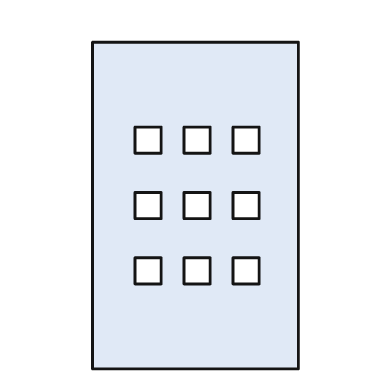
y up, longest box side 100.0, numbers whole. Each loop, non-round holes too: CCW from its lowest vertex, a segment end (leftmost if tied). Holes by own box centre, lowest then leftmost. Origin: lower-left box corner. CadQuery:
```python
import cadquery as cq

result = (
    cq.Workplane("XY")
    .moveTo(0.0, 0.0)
    .lineTo(63.0, 0.0)
    .lineTo(63.0, 100.0)
    .lineTo(0.0, 100.0)
    .close()
    .moveTo(13.0, 26.0)
    .lineTo(21.0, 26.0)
    .lineTo(21.0, 34.0)
    .lineTo(13.0, 34.0)
    .close()
    .moveTo(28.0, 26.0)
    .lineTo(36.0, 26.0)
    .lineTo(36.0, 34.0)
    .lineTo(28.0, 34.0)
    .close()
    .moveTo(43.0, 26.0)
    .lineTo(51.0, 26.0)
    .lineTo(51.0, 34.0)
    .lineTo(43.0, 34.0)
    .close()
    .moveTo(13.0, 46.0)
    .lineTo(21.0, 46.0)
    .lineTo(21.0, 54.0)
    .lineTo(13.0, 54.0)
    .close()
    .moveTo(28.0, 46.0)
    .lineTo(36.0, 46.0)
    .lineTo(36.0, 54.0)
    .lineTo(28.0, 54.0)
    .close()
    .moveTo(43.0, 46.0)
    .lineTo(51.0, 46.0)
    .lineTo(51.0, 54.0)
    .lineTo(43.0, 54.0)
    .close()
    .moveTo(13.0, 66.0)
    .lineTo(21.0, 66.0)
    .lineTo(21.0, 74.0)
    .lineTo(13.0, 74.0)
    .close()
    .moveTo(28.0, 66.0)
    .lineTo(36.0, 66.0)
    .lineTo(36.0, 74.0)
    .lineTo(28.0, 74.0)
    .close()
    .moveTo(43.0, 66.0)
    .lineTo(51.0, 66.0)
    .lineTo(51.0, 74.0)
    .lineTo(43.0, 74.0)
    .close()
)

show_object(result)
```